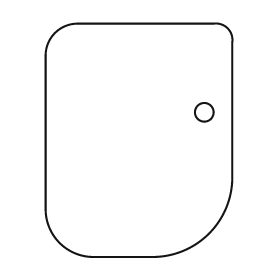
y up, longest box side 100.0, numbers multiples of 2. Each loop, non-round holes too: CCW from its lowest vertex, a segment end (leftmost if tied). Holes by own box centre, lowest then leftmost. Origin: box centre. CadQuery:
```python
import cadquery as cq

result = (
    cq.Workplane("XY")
    .moveTo(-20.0, -50.0)
    .lineTo(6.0, -50.0)
    .threePointArc((30.0, -40.0), (40.0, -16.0))
    .lineTo(40.0, 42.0)
    .threePointArc((38.0, 48.0), (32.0, 50.0))
    .lineTo(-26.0, 50.0)
    .threePointArc((-36.0, 46.0), (-40.0, 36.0))
    .lineTo(-40.0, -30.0)
    .threePointArc((-34.0, -44.0), (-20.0, -50.0))
    .close()
    .moveTo(28.0, 12.0)
    .circle(4.0)
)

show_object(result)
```